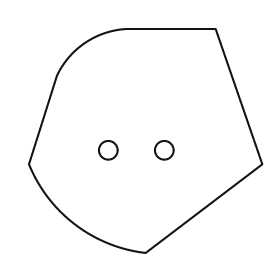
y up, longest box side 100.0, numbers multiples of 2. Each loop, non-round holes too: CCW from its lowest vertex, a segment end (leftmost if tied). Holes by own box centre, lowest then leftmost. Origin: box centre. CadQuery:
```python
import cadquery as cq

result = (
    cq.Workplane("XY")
    .moveTo(0.0, -48.0)
    .lineTo(50.0, -10.0)
    .lineTo(30.0, 48.0)
    .lineTo(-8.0, 48.0)
    .threePointArc((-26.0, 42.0), (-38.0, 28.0))
    .lineTo(-50.0, -10.0)
    .threePointArc((-30.0, -36.0), (0.0, -48.0))
    .close()
    .moveTo(-16.0, -4.0)
    .circle(4.0)
    .moveTo(8.0, -4.0)
    .circle(4.0)
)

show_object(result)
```